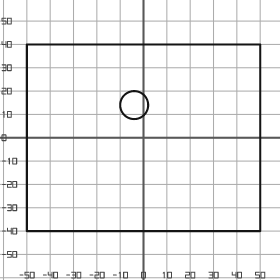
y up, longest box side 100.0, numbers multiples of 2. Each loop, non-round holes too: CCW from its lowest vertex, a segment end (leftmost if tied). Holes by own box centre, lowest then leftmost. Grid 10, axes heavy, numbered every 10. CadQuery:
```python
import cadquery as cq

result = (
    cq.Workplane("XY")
    .moveTo(-50.0, -40.0)
    .lineTo(50.0, -40.0)
    .lineTo(50.0, 40.0)
    .lineTo(-50.0, 40.0)
    .close()
    .moveTo(-4.0, 14.0)
    .circle(6.0)
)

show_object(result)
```